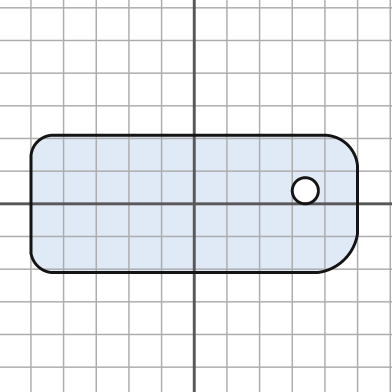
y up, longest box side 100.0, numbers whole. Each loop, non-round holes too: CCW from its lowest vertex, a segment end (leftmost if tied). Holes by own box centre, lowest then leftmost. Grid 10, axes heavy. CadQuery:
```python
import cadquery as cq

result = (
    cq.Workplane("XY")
    .moveTo(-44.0, -21.0)
    .lineTo(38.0, -21.0)
    .threePointArc((46.0, -17.0), (50.0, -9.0))
    .lineTo(50.0, 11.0)
    .threePointArc((47.0, 18.0), (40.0, 21.0))
    .lineTo(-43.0, 21.0)
    .threePointArc((-48.0, 19.0), (-50.0, 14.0))
    .lineTo(-50.0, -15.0)
    .threePointArc((-48.0, -19.0), (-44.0, -21.0))
    .close()
    .moveTo(34.0, 4.0)
    .circle(4.0)
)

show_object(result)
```